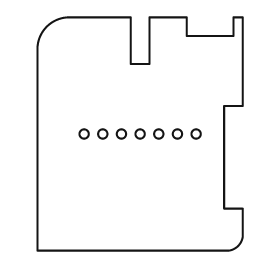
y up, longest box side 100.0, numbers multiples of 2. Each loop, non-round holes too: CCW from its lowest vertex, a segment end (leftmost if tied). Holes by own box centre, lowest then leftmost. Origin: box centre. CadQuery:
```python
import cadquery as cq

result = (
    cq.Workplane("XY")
    .moveTo(-44.0, -50.0)
    .lineTo(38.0, -50.0)
    .threePointArc((42.0, -48.0), (44.0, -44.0))
    .lineTo(44.0, -32.0)
    .lineTo(36.0, -32.0)
    .lineTo(36.0, 12.0)
    .lineTo(44.0, 12.0)
    .lineTo(44.0, 50.0)
    .lineTo(40.0, 50.0)
    .lineTo(40.0, 42.0)
    .lineTo(20.0, 42.0)
    .lineTo(20.0, 50.0)
    .lineTo(4.0, 50.0)
    .lineTo(4.0, 30.0)
    .lineTo(-4.0, 30.0)
    .lineTo(-4.0, 50.0)
    .lineTo(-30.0, 50.0)
    .threePointArc((-40.0, 46.0), (-44.0, 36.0))
    .close()
    .moveTo(-24.0, 0.0)
    .circle(2.0)
    .moveTo(-16.0, 0.0)
    .circle(2.0)
    .moveTo(-8.0, 0.0)
    .circle(2.0)
    .moveTo(0.0, 0.0)
    .circle(2.0)
    .moveTo(8.0, 0.0)
    .circle(2.0)
    .moveTo(16.0, 0.0)
    .circle(2.0)
    .moveTo(24.0, 0.0)
    .circle(2.0)
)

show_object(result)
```